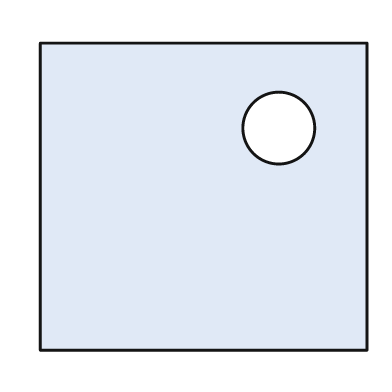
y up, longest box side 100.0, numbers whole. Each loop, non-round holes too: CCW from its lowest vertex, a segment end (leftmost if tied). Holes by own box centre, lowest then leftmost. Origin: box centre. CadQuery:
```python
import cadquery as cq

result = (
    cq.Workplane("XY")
    .moveTo(-50.0, -47.0)
    .lineTo(50.0, -47.0)
    .lineTo(50.0, 47.0)
    .lineTo(-50.0, 47.0)
    .close()
    .moveTo(23.0, 21.0)
    .circle(11.0)
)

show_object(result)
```